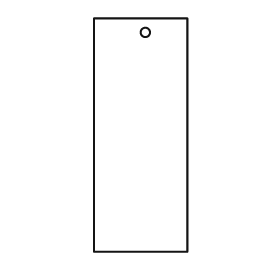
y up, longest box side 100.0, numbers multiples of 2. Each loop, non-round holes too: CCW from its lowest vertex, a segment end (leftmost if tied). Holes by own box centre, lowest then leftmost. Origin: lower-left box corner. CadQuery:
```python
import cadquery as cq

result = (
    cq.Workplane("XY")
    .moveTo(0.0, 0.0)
    .lineTo(40.0, 0.0)
    .lineTo(40.0, 100.0)
    .lineTo(0.0, 100.0)
    .close()
    .moveTo(22.0, 94.0)
    .circle(2.0)
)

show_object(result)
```